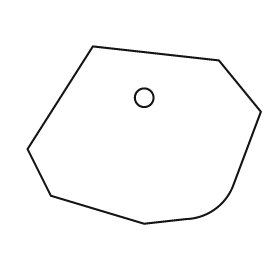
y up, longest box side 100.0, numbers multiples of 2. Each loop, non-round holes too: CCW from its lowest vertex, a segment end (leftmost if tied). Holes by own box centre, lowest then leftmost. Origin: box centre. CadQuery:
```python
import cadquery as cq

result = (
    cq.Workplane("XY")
    .moveTo(0.0, -38.0)
    .lineTo(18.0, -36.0)
    .threePointArc((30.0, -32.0), (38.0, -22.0))
    .lineTo(50.0, 10.0)
    .lineTo(32.0, 32.0)
    .lineTo(-22.0, 38.0)
    .lineTo(-50.0, -6.0)
    .lineTo(-40.0, -26.0)
    .close()
    .moveTo(0.0, 16.0)
    .circle(4.0)
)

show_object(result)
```